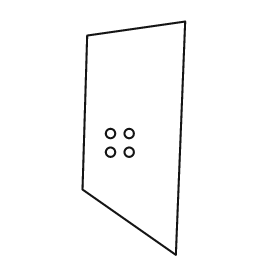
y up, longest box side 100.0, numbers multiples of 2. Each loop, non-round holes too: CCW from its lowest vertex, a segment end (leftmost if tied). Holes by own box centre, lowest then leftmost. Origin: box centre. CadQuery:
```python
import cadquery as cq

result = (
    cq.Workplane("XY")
    .moveTo(18.0, -50.0)
    .lineTo(22.0, 50.0)
    .lineTo(-20.0, 44.0)
    .lineTo(-22.0, -22.0)
    .close()
    .moveTo(-10.0, -6.0)
    .circle(2.0)
    .moveTo(-2.0, -6.0)
    .circle(2.0)
    .moveTo(-10.0, 2.0)
    .circle(2.0)
    .moveTo(-2.0, 2.0)
    .circle(2.0)
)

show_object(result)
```